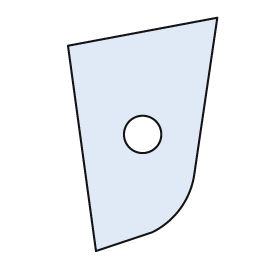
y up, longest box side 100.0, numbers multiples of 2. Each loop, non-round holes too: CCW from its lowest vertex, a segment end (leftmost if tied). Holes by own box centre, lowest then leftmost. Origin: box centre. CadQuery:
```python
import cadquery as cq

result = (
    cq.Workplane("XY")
    .moveTo(-20.0, -50.0)
    .lineTo(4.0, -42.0)
    .threePointArc((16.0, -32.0), (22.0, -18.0))
    .lineTo(32.0, 50.0)
    .lineTo(-32.0, 38.0)
    .close()
    .moveTo(0.0, 0.0)
    .circle(8.0)
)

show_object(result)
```